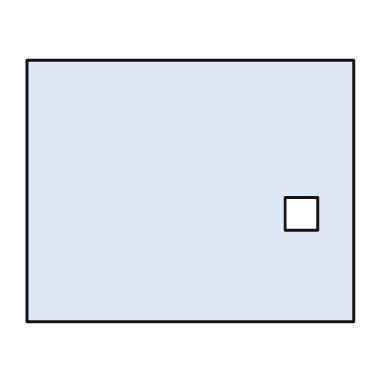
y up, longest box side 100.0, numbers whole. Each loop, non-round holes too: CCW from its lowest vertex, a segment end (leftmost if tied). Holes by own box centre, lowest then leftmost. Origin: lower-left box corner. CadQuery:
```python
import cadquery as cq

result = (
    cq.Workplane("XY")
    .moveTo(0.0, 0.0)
    .lineTo(100.0, 0.0)
    .lineTo(100.0, 80.0)
    .lineTo(0.0, 80.0)
    .close()
    .moveTo(79.0, 28.0)
    .lineTo(89.0, 28.0)
    .lineTo(89.0, 38.0)
    .lineTo(79.0, 38.0)
    .close()
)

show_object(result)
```